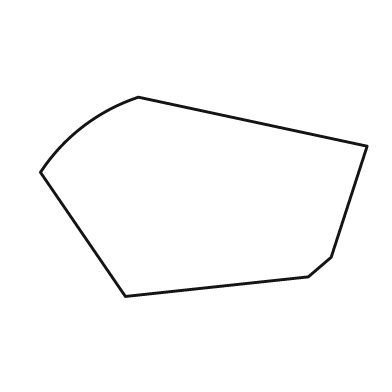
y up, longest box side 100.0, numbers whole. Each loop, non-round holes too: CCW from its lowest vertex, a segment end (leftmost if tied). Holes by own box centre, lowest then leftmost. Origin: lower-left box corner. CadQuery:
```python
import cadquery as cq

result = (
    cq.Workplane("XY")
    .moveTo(26.0, 0.0)
    .lineTo(82.0, 6.0)
    .lineTo(89.0, 12.0)
    .lineTo(100.0, 46.0)
    .lineTo(30.0, 61.0)
    .threePointArc((13.0, 52.0), (0.0, 38.0))
    .close()
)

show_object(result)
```